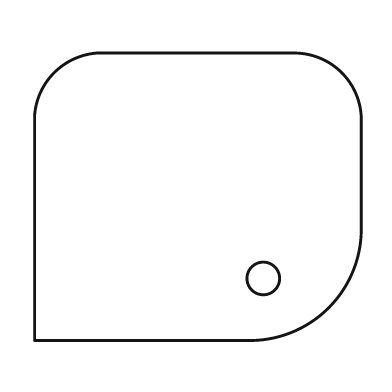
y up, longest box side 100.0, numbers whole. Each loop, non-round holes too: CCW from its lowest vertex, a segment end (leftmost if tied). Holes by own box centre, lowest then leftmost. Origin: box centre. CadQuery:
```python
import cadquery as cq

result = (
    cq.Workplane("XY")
    .moveTo(-50.0, -44.0)
    .lineTo(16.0, -44.0)
    .threePointArc((40.0, -34.0), (50.0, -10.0))
    .lineTo(50.0, 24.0)
    .threePointArc((44.0, 38.0), (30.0, 44.0))
    .lineTo(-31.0, 44.0)
    .threePointArc((-44.0, 38.0), (-50.0, 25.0))
    .close()
    .moveTo(20.0, -25.0)
    .circle(5.0)
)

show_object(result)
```